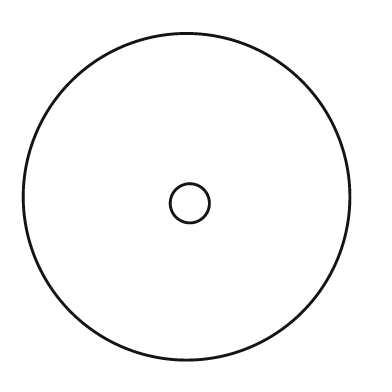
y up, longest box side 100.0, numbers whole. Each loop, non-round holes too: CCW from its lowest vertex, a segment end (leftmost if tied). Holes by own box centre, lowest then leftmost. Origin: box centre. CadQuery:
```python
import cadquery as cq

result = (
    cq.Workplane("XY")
    .moveTo(0.0, 0.0)
    .circle(50.0)
    .moveTo(1.0, -2.0)
    .circle(6.0)
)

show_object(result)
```